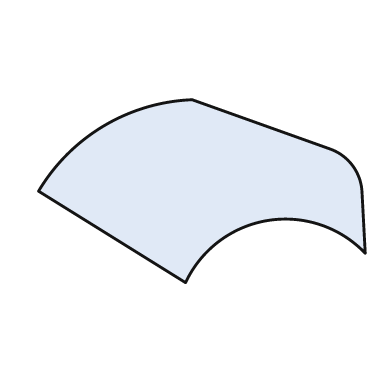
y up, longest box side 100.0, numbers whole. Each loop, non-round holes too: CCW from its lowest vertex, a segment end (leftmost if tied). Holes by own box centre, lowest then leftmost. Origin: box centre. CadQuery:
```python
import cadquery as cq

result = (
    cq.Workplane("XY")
    .moveTo(-5.0, -28.0)
    .threePointArc((20.0, -9.0), (50.0, -19.0))
    .lineTo(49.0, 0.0)
    .threePointArc((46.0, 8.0), (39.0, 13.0))
    .lineTo(-3.0, 28.0)
    .threePointArc((-30.0, 20.0), (-50.0, 0.0))
    .close()
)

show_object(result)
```